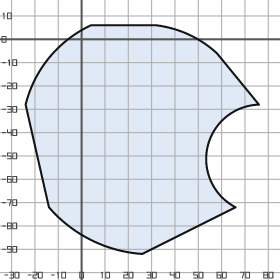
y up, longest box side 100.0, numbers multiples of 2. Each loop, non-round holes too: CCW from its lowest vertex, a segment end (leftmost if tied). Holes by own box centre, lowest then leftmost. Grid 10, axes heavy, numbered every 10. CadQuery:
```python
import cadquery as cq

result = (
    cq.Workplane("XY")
    .moveTo(26.0, -92.0)
    .lineTo(66.0, -72.0)
    .threePointArc((54.0, -46.0), (76.0, -28.0))
    .lineTo(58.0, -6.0)
    .threePointArc((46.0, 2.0), (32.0, 6.0))
    .lineTo(4.0, 6.0)
    .threePointArc((-14.0, -8.0), (-24.0, -28.0))
    .lineTo(-14.0, -72.0)
    .threePointArc((4.0, -86.0), (26.0, -92.0))
    .close()
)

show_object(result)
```